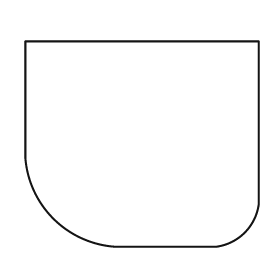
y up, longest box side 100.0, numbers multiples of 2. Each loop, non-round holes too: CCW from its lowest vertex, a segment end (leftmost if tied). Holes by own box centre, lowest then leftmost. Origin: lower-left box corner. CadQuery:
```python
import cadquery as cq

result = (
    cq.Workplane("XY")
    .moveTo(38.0, 0.0)
    .lineTo(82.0, 0.0)
    .threePointArc((94.0, 6.0), (100.0, 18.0))
    .lineTo(100.0, 88.0)
    .lineTo(0.0, 88.0)
    .lineTo(0.0, 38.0)
    .threePointArc((12.0, 12.0), (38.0, 0.0))
    .close()
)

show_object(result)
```